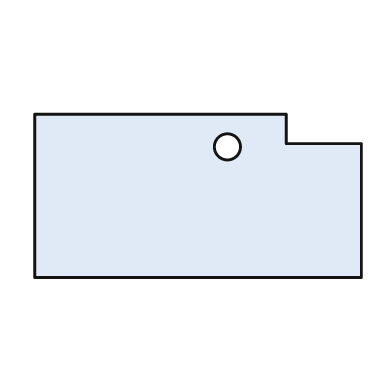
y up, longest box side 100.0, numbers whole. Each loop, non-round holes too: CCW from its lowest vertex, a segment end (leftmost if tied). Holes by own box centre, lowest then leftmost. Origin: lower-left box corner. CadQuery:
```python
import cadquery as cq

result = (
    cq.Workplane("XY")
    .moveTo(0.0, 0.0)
    .lineTo(100.0, 0.0)
    .lineTo(100.0, 41.0)
    .lineTo(77.0, 41.0)
    .lineTo(77.0, 50.0)
    .lineTo(0.0, 50.0)
    .close()
    .moveTo(59.0, 40.0)
    .circle(4.0)
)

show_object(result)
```